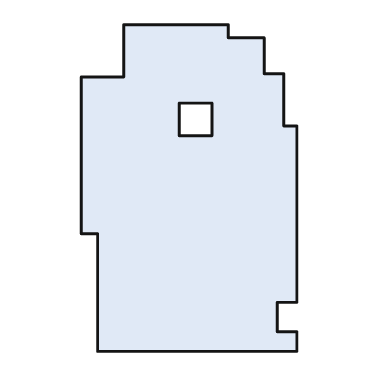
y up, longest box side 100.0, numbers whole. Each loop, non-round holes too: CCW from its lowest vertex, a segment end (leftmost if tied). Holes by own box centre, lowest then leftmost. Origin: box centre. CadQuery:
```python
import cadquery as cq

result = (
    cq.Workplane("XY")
    .moveTo(-28.0, -50.0)
    .lineTo(33.0, -50.0)
    .lineTo(33.0, -44.0)
    .lineTo(27.0, -44.0)
    .lineTo(27.0, -35.0)
    .lineTo(33.0, -35.0)
    .lineTo(33.0, 19.0)
    .lineTo(29.0, 19.0)
    .lineTo(29.0, 35.0)
    .lineTo(23.0, 35.0)
    .lineTo(23.0, 46.0)
    .lineTo(12.0, 46.0)
    .lineTo(12.0, 50.0)
    .lineTo(-20.0, 50.0)
    .lineTo(-20.0, 34.0)
    .lineTo(-33.0, 34.0)
    .lineTo(-33.0, -14.0)
    .lineTo(-28.0, -14.0)
    .close()
    .moveTo(-3.0, 16.0)
    .lineTo(7.0, 16.0)
    .lineTo(7.0, 26.0)
    .lineTo(-3.0, 26.0)
    .close()
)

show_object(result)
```